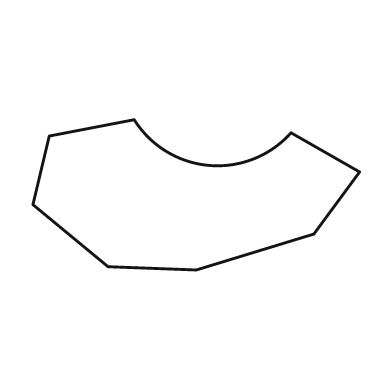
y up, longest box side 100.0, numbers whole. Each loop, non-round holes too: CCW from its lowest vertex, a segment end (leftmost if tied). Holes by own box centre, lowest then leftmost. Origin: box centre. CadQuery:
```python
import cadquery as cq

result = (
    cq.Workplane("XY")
    .moveTo(0.0, -23.0)
    .lineTo(36.0, -12.0)
    .lineTo(50.0, 7.0)
    .lineTo(29.0, 19.0)
    .threePointArc((4.0, 9.0), (-19.0, 23.0))
    .lineTo(-45.0, 18.0)
    .lineTo(-50.0, -3.0)
    .lineTo(-27.0, -22.0)
    .close()
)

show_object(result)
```